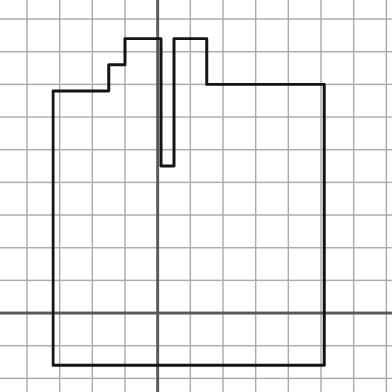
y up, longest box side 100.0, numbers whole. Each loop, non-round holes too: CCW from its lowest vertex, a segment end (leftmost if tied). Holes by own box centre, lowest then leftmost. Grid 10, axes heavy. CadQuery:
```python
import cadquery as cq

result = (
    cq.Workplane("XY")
    .moveTo(-32.0, -16.0)
    .lineTo(51.0, -16.0)
    .lineTo(51.0, 70.0)
    .lineTo(15.0, 70.0)
    .lineTo(15.0, 84.0)
    .lineTo(5.0, 84.0)
    .lineTo(5.0, 45.0)
    .lineTo(1.0, 45.0)
    .lineTo(1.0, 84.0)
    .lineTo(-10.0, 84.0)
    .lineTo(-10.0, 76.0)
    .lineTo(-15.0, 76.0)
    .lineTo(-15.0, 68.0)
    .lineTo(-32.0, 68.0)
    .close()
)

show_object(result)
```